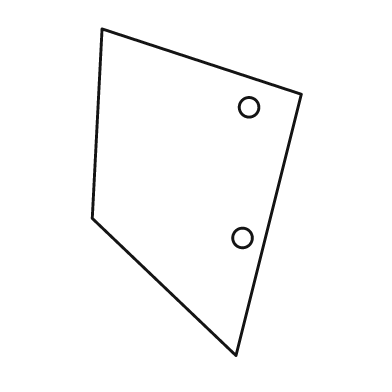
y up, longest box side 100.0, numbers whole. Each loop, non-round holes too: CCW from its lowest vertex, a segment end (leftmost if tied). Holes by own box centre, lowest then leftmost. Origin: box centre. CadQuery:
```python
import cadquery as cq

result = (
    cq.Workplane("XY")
    .moveTo(12.0, -50.0)
    .lineTo(32.0, 30.0)
    .lineTo(-29.0, 50.0)
    .lineTo(-32.0, -8.0)
    .close()
    .moveTo(14.0, -14.0)
    .circle(3.0)
    .moveTo(16.0, 26.0)
    .circle(3.0)
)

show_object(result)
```